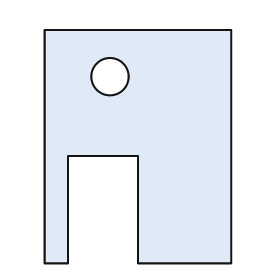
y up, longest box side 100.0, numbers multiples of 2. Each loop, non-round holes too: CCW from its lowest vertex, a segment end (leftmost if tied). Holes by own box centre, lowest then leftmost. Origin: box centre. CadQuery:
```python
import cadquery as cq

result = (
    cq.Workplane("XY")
    .moveTo(-40.0, -50.0)
    .lineTo(-30.0, -50.0)
    .lineTo(-30.0, -4.0)
    .lineTo(0.0, -4.0)
    .lineTo(0.0, -50.0)
    .lineTo(40.0, -50.0)
    .lineTo(40.0, 50.0)
    .lineTo(-40.0, 50.0)
    .close()
    .moveTo(-12.0, 30.0)
    .circle(8.0)
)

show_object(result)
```